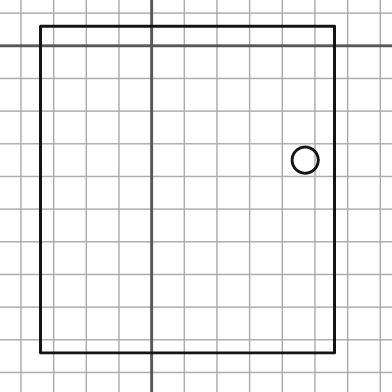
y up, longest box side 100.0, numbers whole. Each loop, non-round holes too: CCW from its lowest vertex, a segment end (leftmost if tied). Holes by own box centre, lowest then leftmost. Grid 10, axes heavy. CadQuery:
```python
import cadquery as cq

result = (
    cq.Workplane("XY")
    .moveTo(-34.0, -94.0)
    .lineTo(56.0, -94.0)
    .lineTo(56.0, 6.0)
    .lineTo(-34.0, 6.0)
    .close()
    .moveTo(47.0, -35.0)
    .circle(4.0)
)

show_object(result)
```